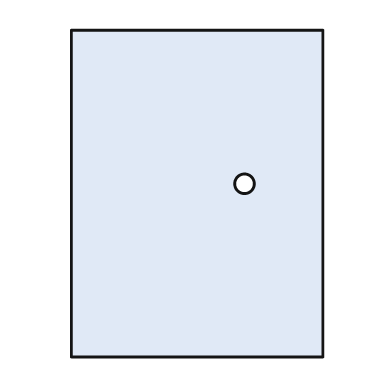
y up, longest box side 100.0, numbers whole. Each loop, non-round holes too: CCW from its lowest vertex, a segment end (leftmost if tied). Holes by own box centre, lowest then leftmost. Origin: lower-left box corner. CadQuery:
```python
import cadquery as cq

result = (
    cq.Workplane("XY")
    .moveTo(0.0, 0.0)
    .lineTo(77.0, 0.0)
    .lineTo(77.0, 100.0)
    .lineTo(0.0, 100.0)
    .close()
    .moveTo(53.0, 53.0)
    .circle(3.0)
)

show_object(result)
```